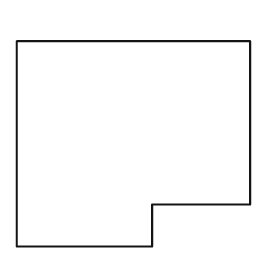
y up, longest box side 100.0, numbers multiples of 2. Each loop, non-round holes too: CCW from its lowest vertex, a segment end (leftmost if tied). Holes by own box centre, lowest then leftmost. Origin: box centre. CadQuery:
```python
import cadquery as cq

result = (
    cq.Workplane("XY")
    .moveTo(-50.0, -44.0)
    .lineTo(8.0, -44.0)
    .lineTo(8.0, -26.0)
    .lineTo(50.0, -26.0)
    .lineTo(50.0, 44.0)
    .lineTo(-50.0, 44.0)
    .close()
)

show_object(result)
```